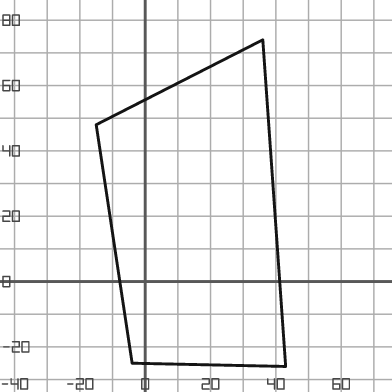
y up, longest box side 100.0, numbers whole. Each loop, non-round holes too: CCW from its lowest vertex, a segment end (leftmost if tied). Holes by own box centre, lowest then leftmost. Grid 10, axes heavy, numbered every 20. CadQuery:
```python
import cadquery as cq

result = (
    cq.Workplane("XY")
    .moveTo(43.0, -26.0)
    .lineTo(36.0, 74.0)
    .lineTo(-15.0, 48.0)
    .lineTo(-4.0, -25.0)
    .close()
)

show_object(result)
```